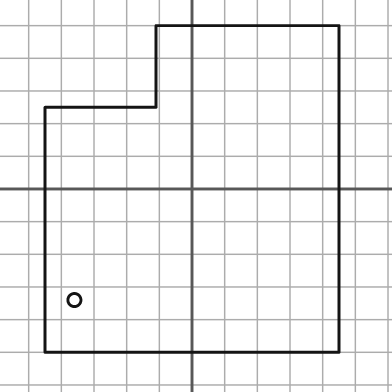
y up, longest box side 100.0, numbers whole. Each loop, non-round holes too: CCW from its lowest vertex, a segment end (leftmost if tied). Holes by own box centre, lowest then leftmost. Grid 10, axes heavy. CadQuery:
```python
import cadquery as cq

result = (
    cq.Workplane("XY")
    .moveTo(-45.0, -50.0)
    .lineTo(45.0, -50.0)
    .lineTo(45.0, 50.0)
    .lineTo(-11.0, 50.0)
    .lineTo(-11.0, 25.0)
    .lineTo(-45.0, 25.0)
    .close()
    .moveTo(-36.0, -34.0)
    .circle(2.0)
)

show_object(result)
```